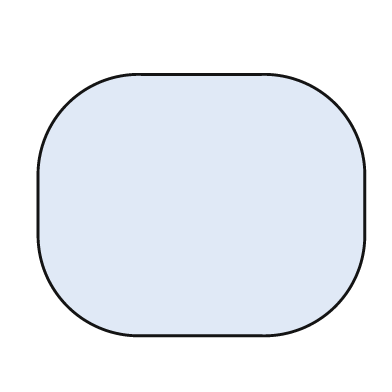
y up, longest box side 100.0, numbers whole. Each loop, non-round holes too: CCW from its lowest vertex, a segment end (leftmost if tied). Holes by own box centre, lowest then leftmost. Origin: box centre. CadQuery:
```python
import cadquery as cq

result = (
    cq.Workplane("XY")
    .moveTo(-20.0, -40.0)
    .lineTo(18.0, -40.0)
    .threePointArc((41.0, -31.0), (50.0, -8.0))
    .lineTo(50.0, 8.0)
    .threePointArc((41.0, 31.0), (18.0, 40.0))
    .lineTo(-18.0, 40.0)
    .threePointArc((-41.0, 31.0), (-50.0, 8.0))
    .lineTo(-50.0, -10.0)
    .threePointArc((-41.0, -31.0), (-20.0, -40.0))
    .close()
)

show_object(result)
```